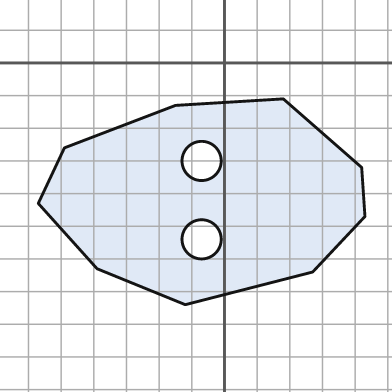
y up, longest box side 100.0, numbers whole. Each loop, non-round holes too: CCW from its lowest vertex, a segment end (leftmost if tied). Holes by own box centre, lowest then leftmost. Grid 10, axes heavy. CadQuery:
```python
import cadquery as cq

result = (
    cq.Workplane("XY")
    .moveTo(-12.0, -74.0)
    .lineTo(27.0, -64.0)
    .lineTo(43.0, -47.0)
    .lineTo(42.0, -32.0)
    .lineTo(18.0, -11.0)
    .lineTo(-15.0, -13.0)
    .lineTo(-49.0, -26.0)
    .lineTo(-57.0, -43.0)
    .lineTo(-39.0, -63.0)
    .close()
    .moveTo(-7.0, -54.0)
    .circle(6.0)
    .moveTo(-7.0, -30.0)
    .circle(6.0)
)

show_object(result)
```